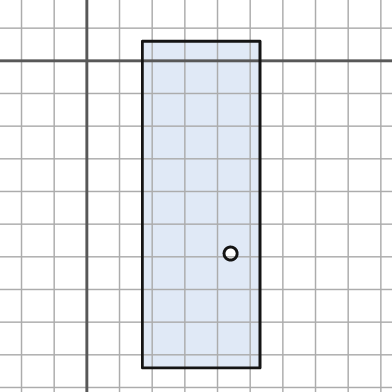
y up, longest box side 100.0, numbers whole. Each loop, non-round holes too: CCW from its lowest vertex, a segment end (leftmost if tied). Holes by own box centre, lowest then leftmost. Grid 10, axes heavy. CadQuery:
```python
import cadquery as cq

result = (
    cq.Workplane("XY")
    .moveTo(17.0, -94.0)
    .lineTo(53.0, -94.0)
    .lineTo(53.0, 6.0)
    .lineTo(17.0, 6.0)
    .close()
    .moveTo(44.0, -59.0)
    .circle(2.0)
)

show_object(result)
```